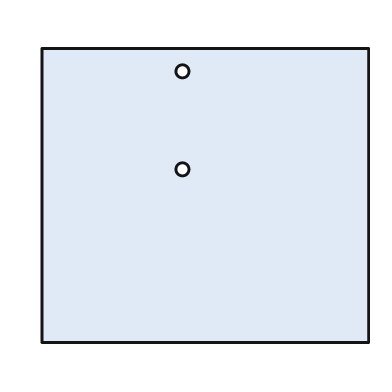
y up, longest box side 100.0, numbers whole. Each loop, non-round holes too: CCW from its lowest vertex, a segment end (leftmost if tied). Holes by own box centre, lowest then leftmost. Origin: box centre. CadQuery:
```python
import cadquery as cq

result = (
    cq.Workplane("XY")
    .moveTo(-50.0, -45.0)
    .lineTo(50.0, -45.0)
    .lineTo(50.0, 45.0)
    .lineTo(-50.0, 45.0)
    .close()
    .moveTo(-7.0, 8.0)
    .circle(2.0)
    .moveTo(-7.0, 38.0)
    .circle(2.0)
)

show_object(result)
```